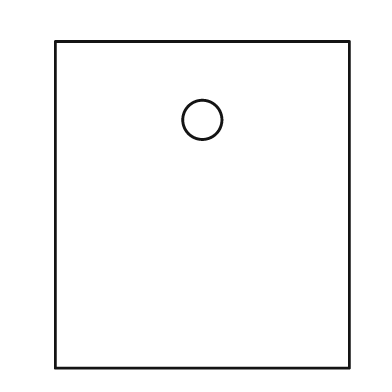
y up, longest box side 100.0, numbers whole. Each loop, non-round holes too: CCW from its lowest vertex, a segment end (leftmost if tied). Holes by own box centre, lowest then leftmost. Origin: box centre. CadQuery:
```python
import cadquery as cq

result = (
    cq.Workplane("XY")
    .moveTo(-45.0, -50.0)
    .lineTo(45.0, -50.0)
    .lineTo(45.0, 50.0)
    .lineTo(-45.0, 50.0)
    .close()
    .moveTo(0.0, 26.0)
    .circle(6.0)
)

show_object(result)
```